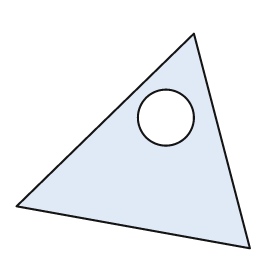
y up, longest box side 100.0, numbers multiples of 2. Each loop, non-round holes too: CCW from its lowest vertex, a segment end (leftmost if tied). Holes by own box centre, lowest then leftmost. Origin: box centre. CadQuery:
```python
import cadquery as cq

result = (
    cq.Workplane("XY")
    .moveTo(50.0, -46.0)
    .lineTo(26.0, 46.0)
    .lineTo(-50.0, -28.0)
    .close()
    .moveTo(14.0, 10.0)
    .circle(12.0)
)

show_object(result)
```